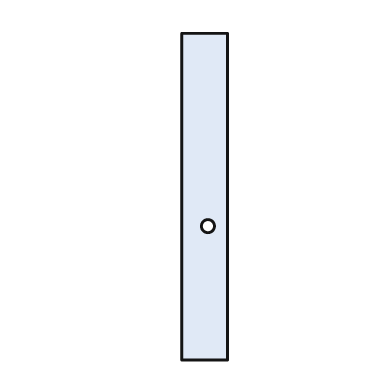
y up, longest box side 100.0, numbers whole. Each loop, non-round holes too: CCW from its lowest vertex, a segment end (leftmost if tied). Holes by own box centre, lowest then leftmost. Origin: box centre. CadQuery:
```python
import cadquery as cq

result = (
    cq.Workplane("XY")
    .moveTo(-7.0, -50.0)
    .lineTo(7.0, -50.0)
    .lineTo(7.0, 50.0)
    .lineTo(-7.0, 50.0)
    .close()
    .moveTo(1.0, -9.0)
    .circle(2.0)
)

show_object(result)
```